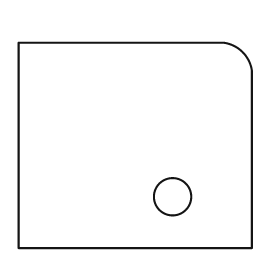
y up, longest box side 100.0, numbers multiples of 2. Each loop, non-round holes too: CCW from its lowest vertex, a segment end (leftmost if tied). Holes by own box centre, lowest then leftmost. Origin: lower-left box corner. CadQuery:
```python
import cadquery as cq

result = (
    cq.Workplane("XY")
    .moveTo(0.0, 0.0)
    .lineTo(100.0, 0.0)
    .lineTo(100.0, 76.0)
    .threePointArc((96.0, 84.0), (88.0, 88.0))
    .lineTo(0.0, 88.0)
    .close()
    .moveTo(66.0, 22.0)
    .circle(8.0)
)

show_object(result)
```